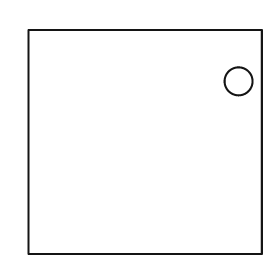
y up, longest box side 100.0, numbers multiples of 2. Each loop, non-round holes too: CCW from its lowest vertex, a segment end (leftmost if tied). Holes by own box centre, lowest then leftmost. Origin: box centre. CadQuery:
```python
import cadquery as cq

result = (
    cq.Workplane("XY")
    .moveTo(-50.0, -48.0)
    .lineTo(50.0, -48.0)
    .lineTo(50.0, 48.0)
    .lineTo(-50.0, 48.0)
    .close()
    .moveTo(40.0, 26.0)
    .circle(6.0)
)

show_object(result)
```